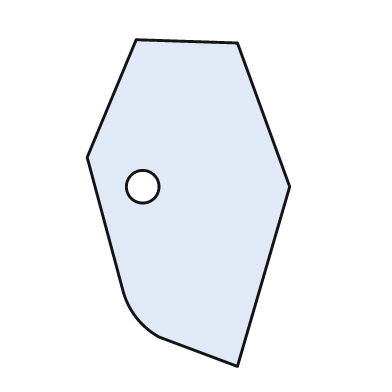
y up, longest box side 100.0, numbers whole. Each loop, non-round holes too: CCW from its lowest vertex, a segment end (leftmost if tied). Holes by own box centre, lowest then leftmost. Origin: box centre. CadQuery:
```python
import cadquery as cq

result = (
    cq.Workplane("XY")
    .moveTo(15.0, -50.0)
    .lineTo(31.0, 5.0)
    .lineTo(15.0, 49.0)
    .lineTo(-16.0, 50.0)
    .lineTo(-31.0, 14.0)
    .lineTo(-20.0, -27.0)
    .threePointArc((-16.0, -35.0), (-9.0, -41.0))
    .close()
    .moveTo(-14.0, 5.0)
    .circle(5.0)
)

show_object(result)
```